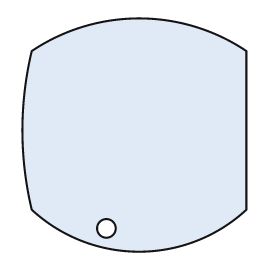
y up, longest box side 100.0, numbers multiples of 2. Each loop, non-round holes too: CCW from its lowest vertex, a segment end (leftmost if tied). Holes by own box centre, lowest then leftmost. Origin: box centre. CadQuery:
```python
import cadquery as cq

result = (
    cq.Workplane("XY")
    .moveTo(-44.0, -32.0)
    .threePointArc((2.0, -50.0), (48.0, -32.0))
    .lineTo(48.0, 36.0)
    .threePointArc((2.0, 50.0), (-44.0, 36.0))
    .threePointArc((-48.0, 2.0), (-44.0, -32.0))
    .close()
    .moveTo(-12.0, -40.0)
    .circle(4.0)
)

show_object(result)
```